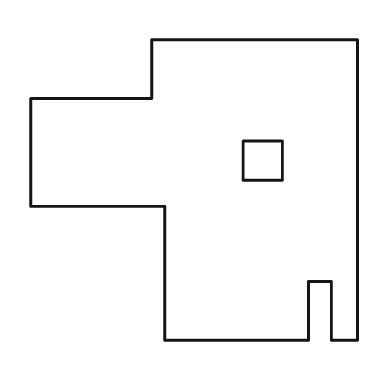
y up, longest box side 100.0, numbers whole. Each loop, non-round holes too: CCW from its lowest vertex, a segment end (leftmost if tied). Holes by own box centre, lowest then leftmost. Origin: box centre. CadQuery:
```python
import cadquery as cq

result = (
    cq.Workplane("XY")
    .moveTo(-9.0, -46.0)
    .lineTo(35.0, -46.0)
    .lineTo(35.0, -28.0)
    .lineTo(42.0, -28.0)
    .lineTo(42.0, -46.0)
    .lineTo(50.0, -46.0)
    .lineTo(50.0, 46.0)
    .lineTo(-13.0, 46.0)
    .lineTo(-13.0, 28.0)
    .lineTo(-50.0, 28.0)
    .lineTo(-50.0, -5.0)
    .lineTo(-9.0, -5.0)
    .close()
    .moveTo(15.0, 3.0)
    .lineTo(27.0, 3.0)
    .lineTo(27.0, 15.0)
    .lineTo(15.0, 15.0)
    .close()
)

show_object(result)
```